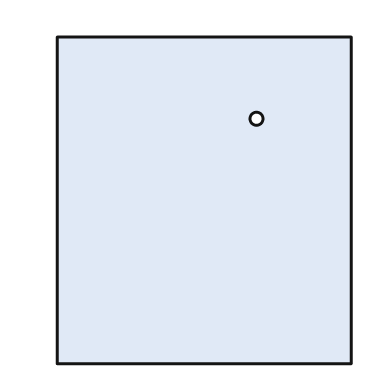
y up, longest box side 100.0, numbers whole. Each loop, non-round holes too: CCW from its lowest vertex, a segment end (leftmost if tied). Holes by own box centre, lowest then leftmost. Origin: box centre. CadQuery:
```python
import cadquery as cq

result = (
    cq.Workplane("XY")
    .moveTo(-45.0, -50.0)
    .lineTo(45.0, -50.0)
    .lineTo(45.0, 50.0)
    .lineTo(-45.0, 50.0)
    .close()
    .moveTo(16.0, 25.0)
    .circle(2.0)
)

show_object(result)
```